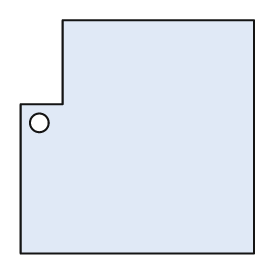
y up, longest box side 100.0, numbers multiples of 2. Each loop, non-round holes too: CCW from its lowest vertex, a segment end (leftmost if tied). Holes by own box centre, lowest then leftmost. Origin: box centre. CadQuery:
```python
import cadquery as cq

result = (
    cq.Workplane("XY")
    .moveTo(-50.0, -50.0)
    .lineTo(50.0, -50.0)
    .lineTo(50.0, 50.0)
    .lineTo(-32.0, 50.0)
    .lineTo(-32.0, 14.0)
    .lineTo(-50.0, 14.0)
    .close()
    .moveTo(-42.0, 6.0)
    .circle(4.0)
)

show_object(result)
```